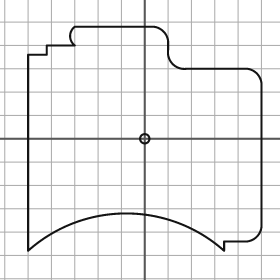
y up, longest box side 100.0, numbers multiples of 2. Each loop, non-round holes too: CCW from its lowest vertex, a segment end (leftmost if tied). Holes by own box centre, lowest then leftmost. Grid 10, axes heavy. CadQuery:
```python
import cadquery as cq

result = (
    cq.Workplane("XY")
    .moveTo(-50.0, -48.0)
    .threePointArc((-8.0, -32.0), (34.0, -48.0))
    .lineTo(34.0, -44.0)
    .lineTo(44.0, -44.0)
    .threePointArc((48.0, -42.0), (50.0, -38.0))
    .lineTo(50.0, 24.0)
    .threePointArc((48.0, 28.0), (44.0, 30.0))
    .lineTo(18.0, 30.0)
    .threePointArc((12.0, 32.0), (10.0, 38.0))
    .lineTo(10.0, 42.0)
    .threePointArc((8.0, 46.0), (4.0, 48.0))
    .lineTo(-30.0, 48.0)
    .threePointArc((-32.0, 44.0), (-30.0, 40.0))
    .lineTo(-42.0, 40.0)
    .lineTo(-42.0, 36.0)
    .lineTo(-50.0, 36.0)
    .close()
    .moveTo(0.0, 0.0)
    .circle(2.0)
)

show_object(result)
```